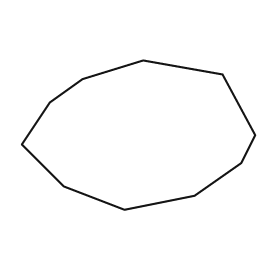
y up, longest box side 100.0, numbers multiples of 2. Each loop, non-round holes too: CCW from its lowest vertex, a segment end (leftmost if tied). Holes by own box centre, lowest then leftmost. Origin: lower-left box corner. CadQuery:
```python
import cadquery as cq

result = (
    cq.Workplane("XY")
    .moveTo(44.0, 0.0)
    .lineTo(74.0, 6.0)
    .lineTo(94.0, 20.0)
    .lineTo(100.0, 32.0)
    .lineTo(86.0, 58.0)
    .lineTo(52.0, 64.0)
    .lineTo(26.0, 56.0)
    .lineTo(12.0, 46.0)
    .lineTo(0.0, 28.0)
    .lineTo(18.0, 10.0)
    .close()
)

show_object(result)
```